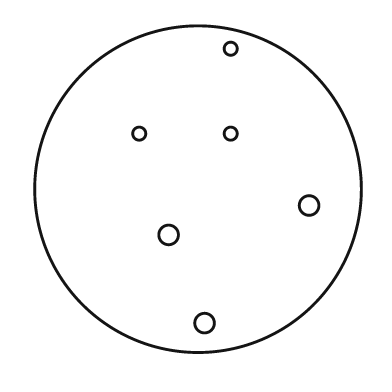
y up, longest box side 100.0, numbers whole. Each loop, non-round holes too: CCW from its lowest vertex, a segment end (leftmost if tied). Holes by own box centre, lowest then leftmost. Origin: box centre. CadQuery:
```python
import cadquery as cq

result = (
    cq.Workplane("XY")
    .moveTo(0.0, 0.0)
    .circle(50.0)
    .moveTo(2.0, -41.0)
    .circle(3.0)
    .moveTo(-9.0, -14.0)
    .circle(3.0)
    .moveTo(34.0, -5.0)
    .circle(3.0)
    .moveTo(-18.0, 17.0)
    .circle(2.0)
    .moveTo(10.0, 17.0)
    .circle(2.0)
    .moveTo(10.0, 43.0)
    .circle(2.0)
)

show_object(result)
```